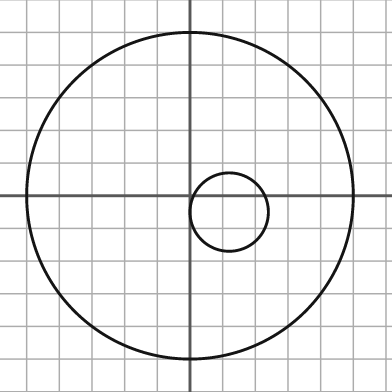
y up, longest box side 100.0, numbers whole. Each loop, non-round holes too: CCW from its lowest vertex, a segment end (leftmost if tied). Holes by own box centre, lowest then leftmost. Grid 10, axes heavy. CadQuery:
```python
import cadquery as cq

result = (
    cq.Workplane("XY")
    .moveTo(0.0, 0.0)
    .circle(50.0)
    .moveTo(12.0, -5.0)
    .circle(12.0)
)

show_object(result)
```